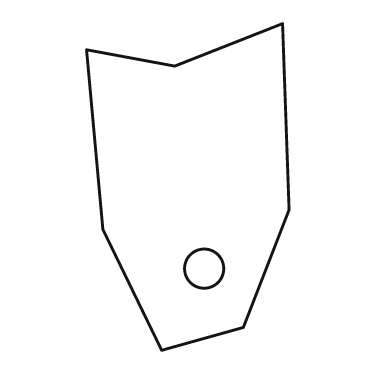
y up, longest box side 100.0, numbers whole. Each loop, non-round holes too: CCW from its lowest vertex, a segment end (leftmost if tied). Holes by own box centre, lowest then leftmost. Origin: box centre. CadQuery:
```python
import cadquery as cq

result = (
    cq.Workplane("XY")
    .moveTo(-8.0, -50.0)
    .lineTo(17.0, -43.0)
    .lineTo(31.0, -7.0)
    .lineTo(29.0, 50.0)
    .lineTo(-4.0, 37.0)
    .lineTo(-31.0, 42.0)
    .lineTo(-26.0, -13.0)
    .close()
    .moveTo(5.0, -25.0)
    .circle(6.0)
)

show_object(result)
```